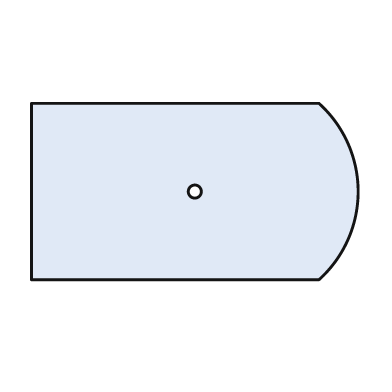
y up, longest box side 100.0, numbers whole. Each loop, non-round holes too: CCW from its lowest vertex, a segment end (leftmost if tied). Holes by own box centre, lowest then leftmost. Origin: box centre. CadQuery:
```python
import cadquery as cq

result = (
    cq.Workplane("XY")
    .moveTo(-50.0, -27.0)
    .lineTo(38.0, -27.0)
    .threePointArc((50.0, 0.0), (38.0, 27.0))
    .lineTo(-50.0, 27.0)
    .close()
    .moveTo(0.0, 0.0)
    .circle(2.0)
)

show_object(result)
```